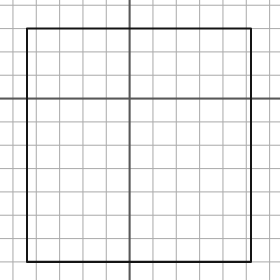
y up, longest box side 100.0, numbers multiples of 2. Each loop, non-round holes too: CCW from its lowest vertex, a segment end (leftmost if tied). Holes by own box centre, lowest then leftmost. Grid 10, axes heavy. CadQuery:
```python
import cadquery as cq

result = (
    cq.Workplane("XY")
    .moveTo(-44.0, -70.0)
    .lineTo(52.0, -70.0)
    .lineTo(52.0, 30.0)
    .lineTo(-44.0, 30.0)
    .close()
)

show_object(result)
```